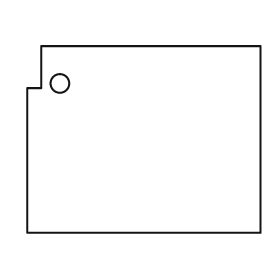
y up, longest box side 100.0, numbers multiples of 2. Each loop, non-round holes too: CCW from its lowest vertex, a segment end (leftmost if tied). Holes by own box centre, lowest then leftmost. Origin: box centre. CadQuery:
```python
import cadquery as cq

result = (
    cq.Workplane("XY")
    .moveTo(-50.0, -40.0)
    .lineTo(50.0, -40.0)
    .lineTo(50.0, 40.0)
    .lineTo(-44.0, 40.0)
    .lineTo(-44.0, 22.0)
    .lineTo(-50.0, 22.0)
    .close()
    .moveTo(-36.0, 24.0)
    .circle(4.0)
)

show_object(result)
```